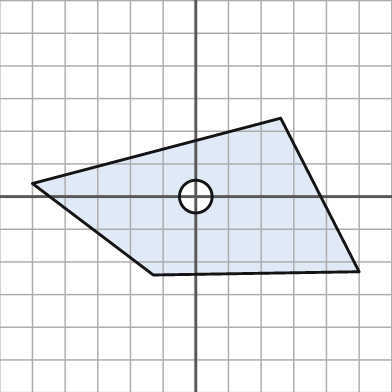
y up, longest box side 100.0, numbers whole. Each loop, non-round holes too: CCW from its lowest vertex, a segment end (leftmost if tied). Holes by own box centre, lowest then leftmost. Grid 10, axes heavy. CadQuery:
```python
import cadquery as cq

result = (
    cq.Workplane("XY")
    .moveTo(-13.0, -24.0)
    .lineTo(50.0, -23.0)
    .lineTo(26.0, 24.0)
    .lineTo(-50.0, 4.0)
    .close()
    .moveTo(0.0, 0.0)
    .circle(5.0)
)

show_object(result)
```